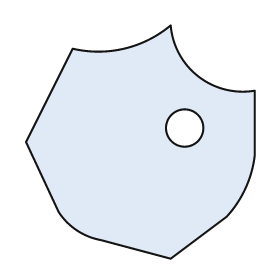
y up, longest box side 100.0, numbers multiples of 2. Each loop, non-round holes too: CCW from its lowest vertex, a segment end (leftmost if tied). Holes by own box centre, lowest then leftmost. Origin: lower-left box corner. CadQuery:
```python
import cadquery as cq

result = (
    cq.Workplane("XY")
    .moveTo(62.0, 0.0)
    .lineTo(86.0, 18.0)
    .threePointArc((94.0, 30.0), (98.0, 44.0))
    .lineTo(98.0, 72.0)
    .threePointArc((74.0, 78.0), (62.0, 100.0))
    .threePointArc((42.0, 90.0), (20.0, 90.0))
    .lineTo(0.0, 50.0)
    .lineTo(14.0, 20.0)
    .threePointArc((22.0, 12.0), (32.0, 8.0))
    .close()
    .moveTo(68.0, 56.0)
    .circle(8.0)
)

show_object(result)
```